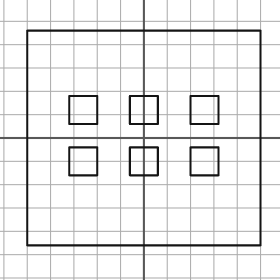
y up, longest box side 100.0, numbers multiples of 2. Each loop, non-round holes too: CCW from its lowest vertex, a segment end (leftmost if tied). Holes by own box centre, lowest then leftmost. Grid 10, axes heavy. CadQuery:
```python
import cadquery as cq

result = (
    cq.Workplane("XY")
    .moveTo(-50.0, -46.0)
    .lineTo(50.0, -46.0)
    .lineTo(50.0, 46.0)
    .lineTo(-50.0, 46.0)
    .close()
    .moveTo(-32.0, -16.0)
    .lineTo(-20.0, -16.0)
    .lineTo(-20.0, -4.0)
    .lineTo(-32.0, -4.0)
    .close()
    .moveTo(-6.0, -16.0)
    .lineTo(6.0, -16.0)
    .lineTo(6.0, -4.0)
    .lineTo(-6.0, -4.0)
    .close()
    .moveTo(20.0, -16.0)
    .lineTo(32.0, -16.0)
    .lineTo(32.0, -4.0)
    .lineTo(20.0, -4.0)
    .close()
    .moveTo(-32.0, 6.0)
    .lineTo(-20.0, 6.0)
    .lineTo(-20.0, 18.0)
    .lineTo(-32.0, 18.0)
    .close()
    .moveTo(-6.0, 6.0)
    .lineTo(6.0, 6.0)
    .lineTo(6.0, 18.0)
    .lineTo(-6.0, 18.0)
    .close()
    .moveTo(20.0, 6.0)
    .lineTo(32.0, 6.0)
    .lineTo(32.0, 18.0)
    .lineTo(20.0, 18.0)
    .close()
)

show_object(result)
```